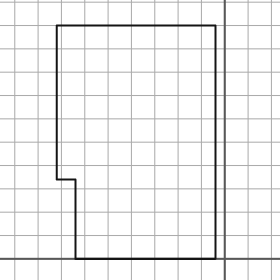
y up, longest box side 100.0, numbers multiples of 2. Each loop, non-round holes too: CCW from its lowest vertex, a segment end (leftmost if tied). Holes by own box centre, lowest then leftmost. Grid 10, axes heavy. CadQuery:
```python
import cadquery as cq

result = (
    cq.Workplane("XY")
    .moveTo(-64.0, 0.0)
    .lineTo(-4.0, 0.0)
    .lineTo(-4.0, 100.0)
    .lineTo(-72.0, 100.0)
    .lineTo(-72.0, 34.0)
    .lineTo(-64.0, 34.0)
    .close()
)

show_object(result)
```